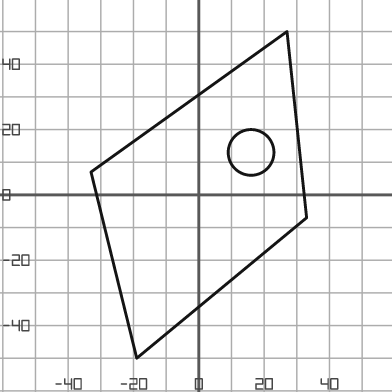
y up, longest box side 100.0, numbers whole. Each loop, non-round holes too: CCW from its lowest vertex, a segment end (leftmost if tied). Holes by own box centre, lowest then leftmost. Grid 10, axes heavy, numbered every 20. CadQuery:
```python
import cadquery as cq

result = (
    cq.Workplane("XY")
    .moveTo(-19.0, -50.0)
    .lineTo(33.0, -7.0)
    .lineTo(27.0, 50.0)
    .lineTo(-33.0, 7.0)
    .close()
    .moveTo(16.0, 13.0)
    .circle(7.0)
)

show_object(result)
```